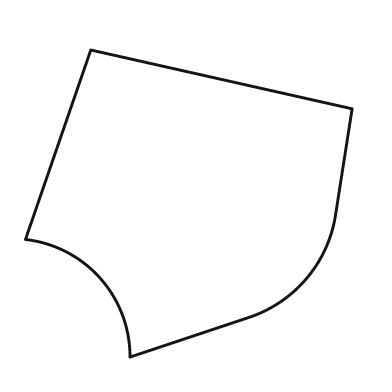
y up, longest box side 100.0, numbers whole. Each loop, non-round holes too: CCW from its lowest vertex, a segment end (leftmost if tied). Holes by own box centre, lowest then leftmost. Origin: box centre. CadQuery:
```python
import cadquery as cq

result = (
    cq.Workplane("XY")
    .moveTo(-18.0, -47.0)
    .lineTo(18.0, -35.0)
    .threePointArc((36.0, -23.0), (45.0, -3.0))
    .lineTo(50.0, 29.0)
    .lineTo(-30.0, 47.0)
    .lineTo(-50.0, -11.0)
    .threePointArc((-27.0, -23.0), (-18.0, -47.0))
    .close()
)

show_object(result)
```